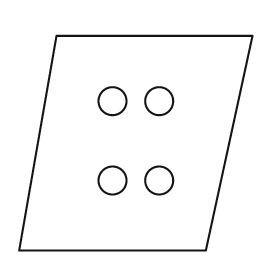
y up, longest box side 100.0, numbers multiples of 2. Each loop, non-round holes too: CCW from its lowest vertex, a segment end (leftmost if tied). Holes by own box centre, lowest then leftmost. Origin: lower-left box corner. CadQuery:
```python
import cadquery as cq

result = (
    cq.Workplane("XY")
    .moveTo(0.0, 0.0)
    .lineTo(80.0, 0.0)
    .lineTo(100.0, 92.0)
    .lineTo(16.0, 92.0)
    .close()
    .moveTo(40.0, 30.0)
    .circle(6.0)
    .moveTo(60.0, 30.0)
    .circle(6.0)
    .moveTo(40.0, 64.0)
    .circle(6.0)
    .moveTo(60.0, 64.0)
    .circle(6.0)
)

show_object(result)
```